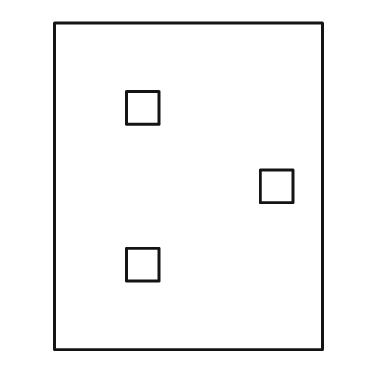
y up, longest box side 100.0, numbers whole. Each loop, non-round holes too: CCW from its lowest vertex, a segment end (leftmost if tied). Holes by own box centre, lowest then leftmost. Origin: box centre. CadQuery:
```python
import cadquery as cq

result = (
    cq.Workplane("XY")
    .moveTo(-41.0, -50.0)
    .lineTo(41.0, -50.0)
    .lineTo(41.0, 50.0)
    .lineTo(-41.0, 50.0)
    .close()
    .moveTo(-19.0, -29.0)
    .lineTo(-9.0, -29.0)
    .lineTo(-9.0, -19.0)
    .lineTo(-19.0, -19.0)
    .close()
    .moveTo(22.0, -5.0)
    .lineTo(32.0, -5.0)
    .lineTo(32.0, 5.0)
    .lineTo(22.0, 5.0)
    .close()
    .moveTo(-19.0, 19.0)
    .lineTo(-9.0, 19.0)
    .lineTo(-9.0, 29.0)
    .lineTo(-19.0, 29.0)
    .close()
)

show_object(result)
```